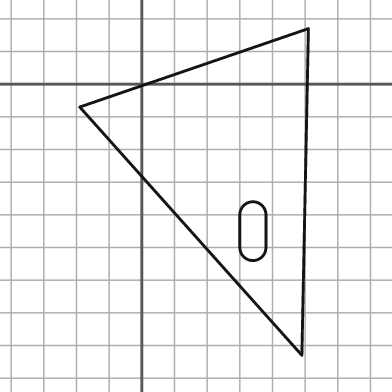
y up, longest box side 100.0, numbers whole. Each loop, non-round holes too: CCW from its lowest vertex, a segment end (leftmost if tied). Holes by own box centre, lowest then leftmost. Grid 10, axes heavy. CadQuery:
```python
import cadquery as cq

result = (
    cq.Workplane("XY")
    .moveTo(49.0, -83.0)
    .lineTo(51.0, 17.0)
    .lineTo(-19.0, -7.0)
    .close()
    .moveTo(30.0, -50.0)
    .threePointArc((34.0, -54.0), (38.0, -50.0))
    .lineTo(38.0, -40.0)
    .threePointArc((34.0, -36.0), (30.0, -40.0))
    .close()
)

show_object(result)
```